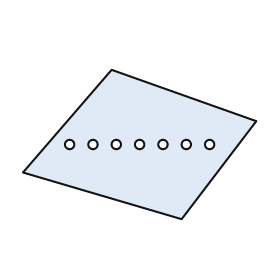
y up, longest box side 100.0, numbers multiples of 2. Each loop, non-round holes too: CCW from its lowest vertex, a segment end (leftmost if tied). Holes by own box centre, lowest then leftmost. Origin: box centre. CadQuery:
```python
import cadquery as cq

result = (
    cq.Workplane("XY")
    .moveTo(18.0, -32.0)
    .lineTo(50.0, 10.0)
    .lineTo(-12.0, 32.0)
    .lineTo(-50.0, -12.0)
    .close()
    .moveTo(-30.0, 0.0)
    .circle(2.0)
    .moveTo(-20.0, 0.0)
    .circle(2.0)
    .moveTo(-10.0, 0.0)
    .circle(2.0)
    .moveTo(0.0, 0.0)
    .circle(2.0)
    .moveTo(10.0, 0.0)
    .circle(2.0)
    .moveTo(20.0, 0.0)
    .circle(2.0)
    .moveTo(30.0, 0.0)
    .circle(2.0)
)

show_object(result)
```